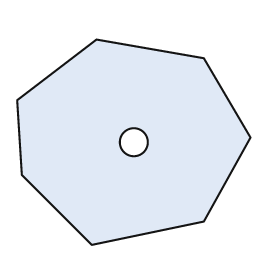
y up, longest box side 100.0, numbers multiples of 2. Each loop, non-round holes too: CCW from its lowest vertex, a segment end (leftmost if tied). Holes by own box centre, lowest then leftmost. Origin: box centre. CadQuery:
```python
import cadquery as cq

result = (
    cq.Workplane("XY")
    .moveTo(-18.0, -44.0)
    .lineTo(30.0, -34.0)
    .lineTo(50.0, 2.0)
    .lineTo(30.0, 36.0)
    .lineTo(-16.0, 44.0)
    .lineTo(-50.0, 18.0)
    .lineTo(-48.0, -14.0)
    .close()
    .moveTo(0.0, 0.0)
    .circle(6.0)
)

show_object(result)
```